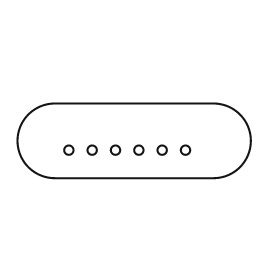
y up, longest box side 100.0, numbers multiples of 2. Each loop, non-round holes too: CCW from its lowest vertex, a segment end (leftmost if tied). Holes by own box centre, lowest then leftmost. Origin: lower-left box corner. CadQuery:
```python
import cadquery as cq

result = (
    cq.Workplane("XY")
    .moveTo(16.0, 0.0)
    .lineTo(84.0, 0.0)
    .threePointArc((100.0, 16.0), (84.0, 32.0))
    .lineTo(16.0, 32.0)
    .threePointArc((0.0, 16.0), (16.0, 0.0))
    .close()
    .moveTo(22.0, 12.0)
    .circle(2.0)
    .moveTo(32.0, 12.0)
    .circle(2.0)
    .moveTo(42.0, 12.0)
    .circle(2.0)
    .moveTo(52.0, 12.0)
    .circle(2.0)
    .moveTo(62.0, 12.0)
    .circle(2.0)
    .moveTo(72.0, 12.0)
    .circle(2.0)
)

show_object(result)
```